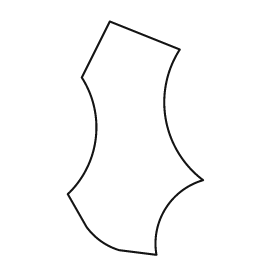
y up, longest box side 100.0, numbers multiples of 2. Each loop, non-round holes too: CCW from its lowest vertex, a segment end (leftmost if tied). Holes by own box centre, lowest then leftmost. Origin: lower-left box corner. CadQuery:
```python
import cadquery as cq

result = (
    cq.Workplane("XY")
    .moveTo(38.0, 0.0)
    .threePointArc((42.0, 20.0), (58.0, 32.0))
    .threePointArc((42.0, 58.0), (48.0, 88.0))
    .lineTo(18.0, 100.0)
    .lineTo(6.0, 76.0)
    .threePointArc((12.0, 50.0), (0.0, 26.0))
    .lineTo(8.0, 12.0)
    .threePointArc((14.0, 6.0), (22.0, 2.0))
    .close()
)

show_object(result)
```